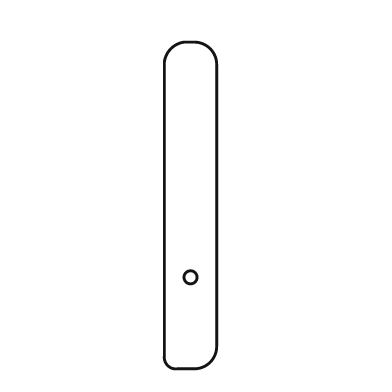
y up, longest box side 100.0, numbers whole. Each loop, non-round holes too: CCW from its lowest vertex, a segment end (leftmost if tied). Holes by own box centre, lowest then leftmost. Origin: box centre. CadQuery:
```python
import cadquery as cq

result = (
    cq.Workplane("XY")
    .moveTo(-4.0, -50.0)
    .lineTo(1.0, -50.0)
    .threePointArc((6.0, -48.0), (8.0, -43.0))
    .lineTo(8.0, 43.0)
    .threePointArc((6.0, 48.0), (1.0, 50.0))
    .lineTo(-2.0, 50.0)
    .threePointArc((-6.0, 48.0), (-8.0, 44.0))
    .lineTo(-8.0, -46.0)
    .threePointArc((-7.0, -49.0), (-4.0, -50.0))
    .close()
    .moveTo(0.0, -22.0)
    .circle(2.0)
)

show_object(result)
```